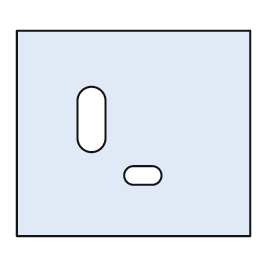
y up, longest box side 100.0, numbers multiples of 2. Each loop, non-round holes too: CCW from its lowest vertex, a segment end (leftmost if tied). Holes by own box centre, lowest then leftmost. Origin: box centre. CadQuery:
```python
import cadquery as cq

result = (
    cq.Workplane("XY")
    .moveTo(-50.0, -44.0)
    .lineTo(50.0, -44.0)
    .lineTo(50.0, 44.0)
    .lineTo(-50.0, 44.0)
    .close()
    .moveTo(0.0, -22.0)
    .lineTo(8.0, -22.0)
    .threePointArc((12.0, -18.0), (8.0, -14.0))
    .lineTo(0.0, -14.0)
    .threePointArc((-4.0, -18.0), (0.0, -22.0))
    .close()
    .moveTo(-24.0, -2.0)
    .threePointArc((-18.0, -8.0), (-12.0, -2.0))
    .lineTo(-12.0, 14.0)
    .threePointArc((-18.0, 20.0), (-24.0, 14.0))
    .close()
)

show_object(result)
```